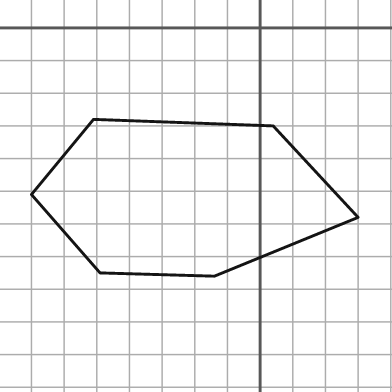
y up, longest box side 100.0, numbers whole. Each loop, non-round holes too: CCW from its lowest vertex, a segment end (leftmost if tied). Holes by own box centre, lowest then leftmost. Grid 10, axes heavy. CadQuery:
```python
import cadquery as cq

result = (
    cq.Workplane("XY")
    .moveTo(-14.0, -76.0)
    .lineTo(30.0, -58.0)
    .lineTo(4.0, -30.0)
    .lineTo(-51.0, -28.0)
    .lineTo(-70.0, -51.0)
    .lineTo(-49.0, -75.0)
    .close()
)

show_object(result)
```